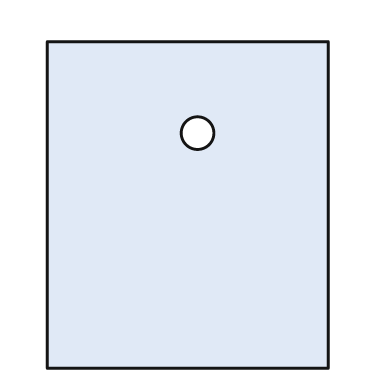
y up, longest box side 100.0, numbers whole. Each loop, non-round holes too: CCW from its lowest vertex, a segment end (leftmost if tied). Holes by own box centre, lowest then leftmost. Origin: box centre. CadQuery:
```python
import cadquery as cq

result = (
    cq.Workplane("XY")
    .moveTo(-43.0, -50.0)
    .lineTo(43.0, -50.0)
    .lineTo(43.0, 50.0)
    .lineTo(-43.0, 50.0)
    .close()
    .moveTo(3.0, 22.0)
    .circle(5.0)
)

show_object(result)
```